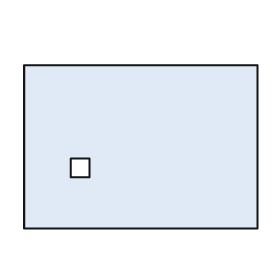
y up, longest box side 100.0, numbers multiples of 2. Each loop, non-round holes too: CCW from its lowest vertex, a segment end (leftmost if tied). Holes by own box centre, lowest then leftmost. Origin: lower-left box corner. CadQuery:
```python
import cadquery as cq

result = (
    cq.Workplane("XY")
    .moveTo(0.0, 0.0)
    .lineTo(100.0, 0.0)
    .lineTo(100.0, 70.0)
    .lineTo(0.0, 70.0)
    .close()
    .moveTo(20.0, 22.0)
    .lineTo(28.0, 22.0)
    .lineTo(28.0, 30.0)
    .lineTo(20.0, 30.0)
    .close()
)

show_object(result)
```